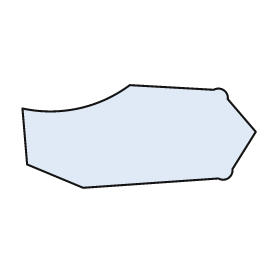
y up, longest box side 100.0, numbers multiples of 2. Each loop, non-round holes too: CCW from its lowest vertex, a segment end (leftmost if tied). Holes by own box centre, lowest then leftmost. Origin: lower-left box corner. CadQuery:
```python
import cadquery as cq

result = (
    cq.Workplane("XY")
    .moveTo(26.0, 0.0)
    .lineTo(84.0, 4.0)
    .threePointArc((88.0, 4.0), (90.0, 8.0))
    .lineTo(100.0, 24.0)
    .lineTo(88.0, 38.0)
    .threePointArc((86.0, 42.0), (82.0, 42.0))
    .lineTo(46.0, 44.0)
    .threePointArc((24.0, 34.0), (0.0, 34.0))
    .lineTo(2.0, 10.0)
    .close()
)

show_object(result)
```